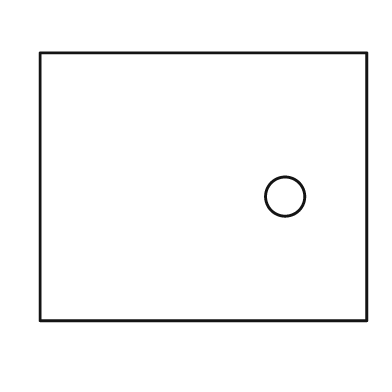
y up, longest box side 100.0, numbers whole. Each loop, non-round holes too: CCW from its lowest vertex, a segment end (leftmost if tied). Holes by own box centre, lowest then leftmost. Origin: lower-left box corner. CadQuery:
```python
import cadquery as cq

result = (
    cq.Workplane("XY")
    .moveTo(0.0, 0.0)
    .lineTo(100.0, 0.0)
    .lineTo(100.0, 82.0)
    .lineTo(0.0, 82.0)
    .close()
    .moveTo(75.0, 38.0)
    .circle(6.0)
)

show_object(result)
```